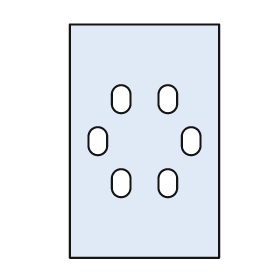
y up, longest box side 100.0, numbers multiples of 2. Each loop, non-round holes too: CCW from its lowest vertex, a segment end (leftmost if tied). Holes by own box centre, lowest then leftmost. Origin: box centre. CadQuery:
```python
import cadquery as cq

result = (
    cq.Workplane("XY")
    .moveTo(-32.0, -50.0)
    .lineTo(32.0, -50.0)
    .lineTo(32.0, 50.0)
    .lineTo(-32.0, 50.0)
    .close()
    .moveTo(-14.0, -20.0)
    .threePointArc((-10.0, -24.0), (-6.0, -20.0))
    .lineTo(-6.0, -16.0)
    .threePointArc((-10.0, -12.0), (-14.0, -16.0))
    .close()
    .moveTo(6.0, -20.0)
    .threePointArc((10.0, -24.0), (14.0, -20.0))
    .lineTo(14.0, -16.0)
    .threePointArc((10.0, -12.0), (6.0, -16.0))
    .close()
    .moveTo(-24.0, -2.0)
    .threePointArc((-20.0, -6.0), (-16.0, -2.0))
    .lineTo(-16.0, 2.0)
    .threePointArc((-20.0, 6.0), (-24.0, 2.0))
    .close()
    .moveTo(16.0, -2.0)
    .threePointArc((20.0, -6.0), (24.0, -2.0))
    .lineTo(24.0, 2.0)
    .threePointArc((20.0, 6.0), (16.0, 2.0))
    .close()
    .moveTo(-14.0, 16.0)
    .threePointArc((-10.0, 12.0), (-6.0, 16.0))
    .lineTo(-6.0, 20.0)
    .threePointArc((-10.0, 24.0), (-14.0, 20.0))
    .close()
    .moveTo(6.0, 16.0)
    .threePointArc((10.0, 12.0), (14.0, 16.0))
    .lineTo(14.0, 20.0)
    .threePointArc((10.0, 24.0), (6.0, 20.0))
    .close()
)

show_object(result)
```